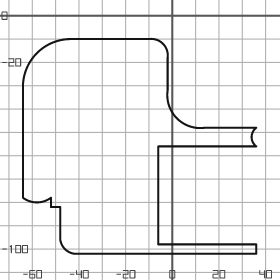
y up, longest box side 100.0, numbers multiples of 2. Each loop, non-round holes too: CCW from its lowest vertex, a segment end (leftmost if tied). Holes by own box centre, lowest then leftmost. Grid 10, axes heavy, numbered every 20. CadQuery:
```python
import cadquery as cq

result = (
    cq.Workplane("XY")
    .moveTo(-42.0, -102.0)
    .lineTo(36.0, -102.0)
    .lineTo(36.0, -98.0)
    .lineTo(-6.0, -98.0)
    .lineTo(-6.0, -56.0)
    .lineTo(36.0, -56.0)
    .threePointArc((34.0, -52.0), (36.0, -48.0))
    .lineTo(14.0, -48.0)
    .threePointArc((2.0, -44.0), (-2.0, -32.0))
    .lineTo(-2.0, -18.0)
    .threePointArc((-4.0, -12.0), (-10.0, -10.0))
    .lineTo(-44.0, -10.0)
    .threePointArc((-58.0, -16.0), (-64.0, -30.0))
    .lineTo(-64.0, -78.0)
    .threePointArc((-58.0, -80.0), (-52.0, -78.0))
    .lineTo(-52.0, -82.0)
    .lineTo(-48.0, -82.0)
    .lineTo(-48.0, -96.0)
    .threePointArc((-46.0, -100.0), (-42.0, -102.0))
    .close()
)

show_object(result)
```